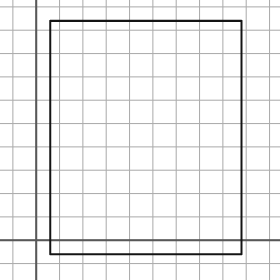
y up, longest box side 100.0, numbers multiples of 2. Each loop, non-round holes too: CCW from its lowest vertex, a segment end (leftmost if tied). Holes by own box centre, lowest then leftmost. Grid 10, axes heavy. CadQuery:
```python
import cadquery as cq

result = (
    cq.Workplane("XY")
    .moveTo(6.0, -6.0)
    .lineTo(88.0, -6.0)
    .lineTo(88.0, 94.0)
    .lineTo(6.0, 94.0)
    .close()
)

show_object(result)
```